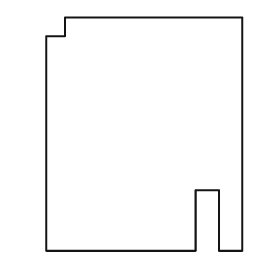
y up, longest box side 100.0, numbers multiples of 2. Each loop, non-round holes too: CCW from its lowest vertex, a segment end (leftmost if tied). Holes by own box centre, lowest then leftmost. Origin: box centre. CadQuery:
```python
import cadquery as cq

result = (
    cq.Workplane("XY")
    .moveTo(-42.0, -50.0)
    .lineTo(22.0, -50.0)
    .lineTo(22.0, -24.0)
    .lineTo(32.0, -24.0)
    .lineTo(32.0, -50.0)
    .lineTo(42.0, -50.0)
    .lineTo(42.0, 50.0)
    .lineTo(-34.0, 50.0)
    .lineTo(-34.0, 42.0)
    .lineTo(-42.0, 42.0)
    .close()
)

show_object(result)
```